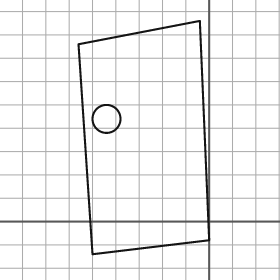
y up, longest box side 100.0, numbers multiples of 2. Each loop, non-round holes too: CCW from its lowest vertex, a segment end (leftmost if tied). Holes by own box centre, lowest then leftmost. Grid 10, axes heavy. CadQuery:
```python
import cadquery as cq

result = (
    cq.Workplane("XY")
    .moveTo(-50.0, -14.0)
    .lineTo(0.0, -8.0)
    .lineTo(-4.0, 86.0)
    .lineTo(-56.0, 76.0)
    .close()
    .moveTo(-44.0, 44.0)
    .circle(6.0)
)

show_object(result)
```